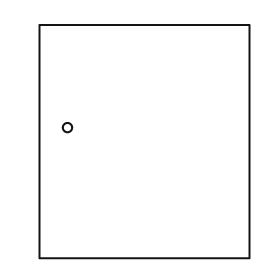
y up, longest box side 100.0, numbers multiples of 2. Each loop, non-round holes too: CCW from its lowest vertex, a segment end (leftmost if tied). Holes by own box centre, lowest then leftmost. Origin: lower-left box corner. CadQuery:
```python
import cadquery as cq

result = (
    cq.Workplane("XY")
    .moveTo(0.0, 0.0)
    .lineTo(90.0, 0.0)
    .lineTo(90.0, 100.0)
    .lineTo(0.0, 100.0)
    .close()
    .moveTo(12.0, 56.0)
    .circle(2.0)
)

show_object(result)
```